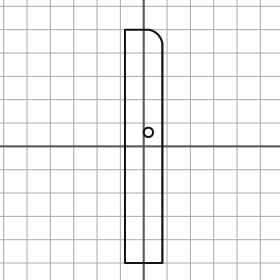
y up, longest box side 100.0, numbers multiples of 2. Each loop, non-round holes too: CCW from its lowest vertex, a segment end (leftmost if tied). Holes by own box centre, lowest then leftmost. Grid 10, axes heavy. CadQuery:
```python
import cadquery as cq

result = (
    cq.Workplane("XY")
    .moveTo(-8.0, -50.0)
    .lineTo(8.0, -50.0)
    .lineTo(8.0, 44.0)
    .threePointArc((6.0, 48.0), (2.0, 50.0))
    .lineTo(-8.0, 50.0)
    .close()
    .moveTo(2.0, 6.0)
    .circle(2.0)
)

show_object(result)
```